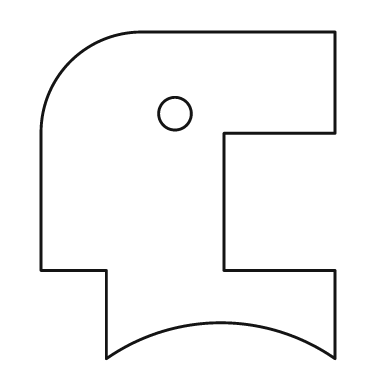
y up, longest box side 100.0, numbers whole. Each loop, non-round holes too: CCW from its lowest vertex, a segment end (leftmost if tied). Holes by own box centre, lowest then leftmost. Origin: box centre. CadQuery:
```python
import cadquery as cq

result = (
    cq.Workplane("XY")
    .moveTo(-25.0, -50.0)
    .threePointArc((10.0, -39.0), (45.0, -50.0))
    .lineTo(45.0, -23.0)
    .lineTo(11.0, -23.0)
    .lineTo(11.0, 19.0)
    .lineTo(45.0, 19.0)
    .lineTo(45.0, 50.0)
    .lineTo(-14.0, 50.0)
    .threePointArc((-36.0, 41.0), (-45.0, 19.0))
    .lineTo(-45.0, -23.0)
    .lineTo(-25.0, -23.0)
    .close()
    .moveTo(-4.0, 25.0)
    .circle(5.0)
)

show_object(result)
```